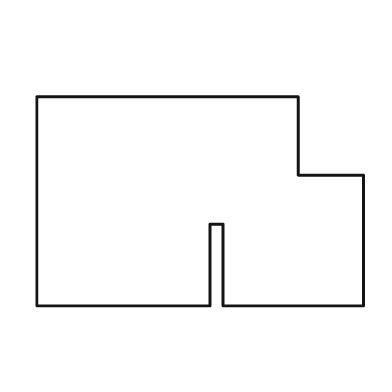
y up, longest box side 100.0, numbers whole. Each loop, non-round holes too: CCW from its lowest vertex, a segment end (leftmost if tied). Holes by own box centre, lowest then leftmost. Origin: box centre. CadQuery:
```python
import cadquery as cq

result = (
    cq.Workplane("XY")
    .moveTo(-50.0, -32.0)
    .lineTo(3.0, -32.0)
    .lineTo(3.0, -7.0)
    .lineTo(7.0, -7.0)
    .lineTo(7.0, -32.0)
    .lineTo(50.0, -32.0)
    .lineTo(50.0, 8.0)
    .lineTo(30.0, 8.0)
    .lineTo(30.0, 32.0)
    .lineTo(-50.0, 32.0)
    .close()
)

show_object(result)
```